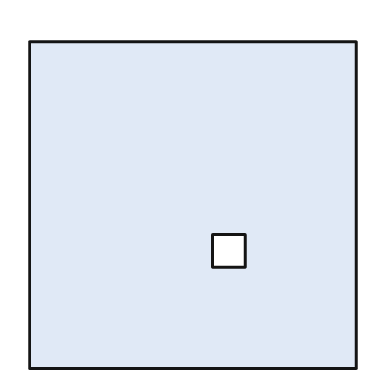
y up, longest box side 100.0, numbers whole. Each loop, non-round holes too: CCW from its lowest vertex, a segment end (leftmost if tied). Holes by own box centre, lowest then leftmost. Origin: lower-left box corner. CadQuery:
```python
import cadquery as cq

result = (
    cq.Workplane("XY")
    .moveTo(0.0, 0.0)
    .lineTo(100.0, 0.0)
    .lineTo(100.0, 100.0)
    .lineTo(0.0, 100.0)
    .close()
    .moveTo(56.0, 31.0)
    .lineTo(66.0, 31.0)
    .lineTo(66.0, 41.0)
    .lineTo(56.0, 41.0)
    .close()
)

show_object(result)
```